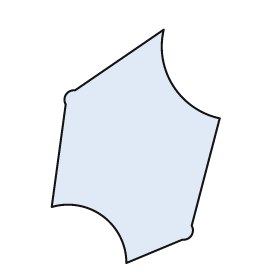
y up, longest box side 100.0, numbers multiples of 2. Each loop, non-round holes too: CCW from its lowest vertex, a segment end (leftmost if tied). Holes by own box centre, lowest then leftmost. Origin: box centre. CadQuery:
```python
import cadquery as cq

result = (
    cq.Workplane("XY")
    .moveTo(-4.0, -50.0)
    .lineTo(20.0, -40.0)
    .threePointArc((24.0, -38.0), (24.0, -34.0))
    .lineTo(36.0, 12.0)
    .threePointArc((16.0, 26.0), (12.0, 50.0))
    .lineTo(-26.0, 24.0)
    .threePointArc((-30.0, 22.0), (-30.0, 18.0))
    .lineTo(-36.0, -26.0)
    .threePointArc((-14.0, -30.0), (-4.0, -50.0))
    .close()
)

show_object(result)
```